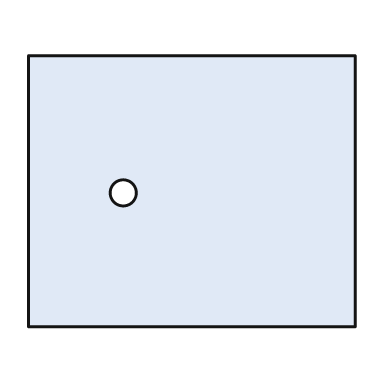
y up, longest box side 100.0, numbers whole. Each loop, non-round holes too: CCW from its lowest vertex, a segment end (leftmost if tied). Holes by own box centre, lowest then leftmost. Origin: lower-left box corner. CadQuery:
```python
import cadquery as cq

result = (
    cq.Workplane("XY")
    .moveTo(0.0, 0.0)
    .lineTo(100.0, 0.0)
    .lineTo(100.0, 83.0)
    .lineTo(0.0, 83.0)
    .close()
    .moveTo(29.0, 41.0)
    .circle(4.0)
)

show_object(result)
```